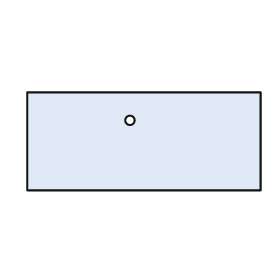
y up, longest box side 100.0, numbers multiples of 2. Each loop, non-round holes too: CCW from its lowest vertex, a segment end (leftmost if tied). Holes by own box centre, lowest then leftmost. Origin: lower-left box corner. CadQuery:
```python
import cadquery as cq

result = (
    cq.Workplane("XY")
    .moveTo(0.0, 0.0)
    .lineTo(100.0, 0.0)
    .lineTo(100.0, 42.0)
    .lineTo(0.0, 42.0)
    .close()
    .moveTo(44.0, 30.0)
    .circle(2.0)
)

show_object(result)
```